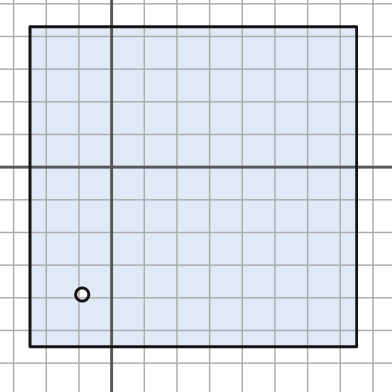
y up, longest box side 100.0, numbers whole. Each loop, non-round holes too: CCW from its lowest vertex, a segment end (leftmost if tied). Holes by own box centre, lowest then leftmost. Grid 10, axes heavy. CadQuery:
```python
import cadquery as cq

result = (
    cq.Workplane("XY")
    .moveTo(-25.0, -55.0)
    .lineTo(75.0, -55.0)
    .lineTo(75.0, 43.0)
    .lineTo(-25.0, 43.0)
    .close()
    .moveTo(-9.0, -39.0)
    .circle(2.0)
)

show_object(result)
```